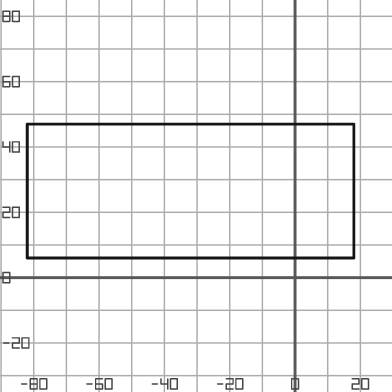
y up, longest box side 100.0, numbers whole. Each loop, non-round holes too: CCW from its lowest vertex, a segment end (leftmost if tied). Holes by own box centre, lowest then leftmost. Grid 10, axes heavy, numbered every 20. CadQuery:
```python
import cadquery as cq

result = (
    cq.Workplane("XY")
    .moveTo(-82.0, 6.0)
    .lineTo(18.0, 6.0)
    .lineTo(18.0, 47.0)
    .lineTo(-82.0, 47.0)
    .close()
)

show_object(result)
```